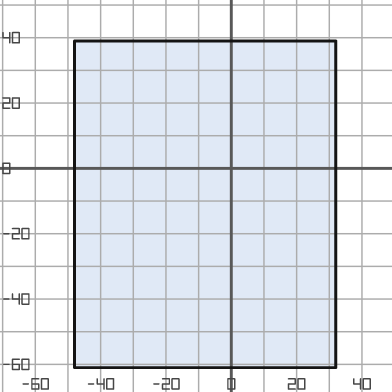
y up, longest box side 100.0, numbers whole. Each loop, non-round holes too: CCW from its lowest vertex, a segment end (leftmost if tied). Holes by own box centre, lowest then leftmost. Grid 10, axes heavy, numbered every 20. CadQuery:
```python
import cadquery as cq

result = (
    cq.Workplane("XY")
    .moveTo(-48.0, -61.0)
    .lineTo(32.0, -61.0)
    .lineTo(32.0, 39.0)
    .lineTo(-48.0, 39.0)
    .close()
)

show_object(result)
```